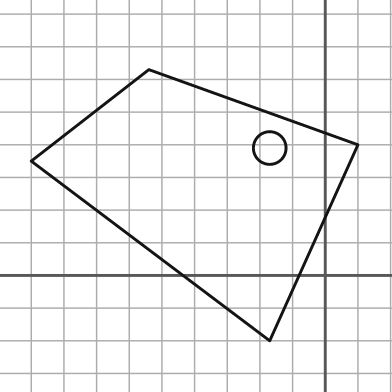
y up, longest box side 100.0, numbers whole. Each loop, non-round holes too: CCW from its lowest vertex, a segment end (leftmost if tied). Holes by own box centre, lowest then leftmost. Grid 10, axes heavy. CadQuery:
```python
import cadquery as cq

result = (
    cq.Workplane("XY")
    .moveTo(-17.0, -20.0)
    .lineTo(10.0, 40.0)
    .lineTo(-54.0, 63.0)
    .lineTo(-90.0, 35.0)
    .close()
    .moveTo(-17.0, 39.0)
    .circle(5.0)
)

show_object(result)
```